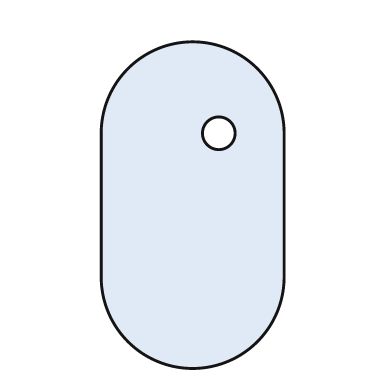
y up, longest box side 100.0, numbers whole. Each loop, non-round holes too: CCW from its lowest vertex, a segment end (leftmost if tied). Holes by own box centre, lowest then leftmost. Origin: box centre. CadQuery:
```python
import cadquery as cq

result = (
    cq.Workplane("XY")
    .moveTo(-28.0, -22.0)
    .threePointArc((0.0, -50.0), (28.0, -22.0))
    .lineTo(28.0, 22.0)
    .threePointArc((0.0, 50.0), (-28.0, 22.0))
    .close()
    .moveTo(8.0, 22.0)
    .circle(5.0)
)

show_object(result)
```